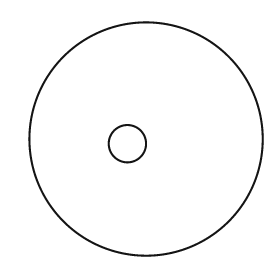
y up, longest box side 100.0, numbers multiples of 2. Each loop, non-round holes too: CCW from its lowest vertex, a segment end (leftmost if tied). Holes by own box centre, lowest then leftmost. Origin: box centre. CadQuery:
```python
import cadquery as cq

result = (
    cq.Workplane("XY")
    .moveTo(0.0, 0.0)
    .circle(50.0)
    .moveTo(-8.0, -2.0)
    .circle(8.0)
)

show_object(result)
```